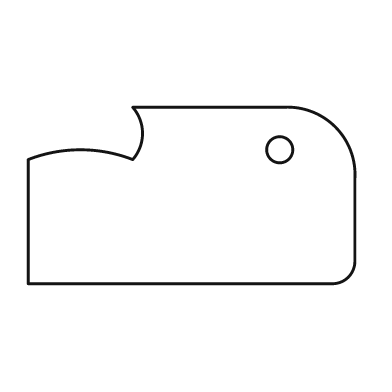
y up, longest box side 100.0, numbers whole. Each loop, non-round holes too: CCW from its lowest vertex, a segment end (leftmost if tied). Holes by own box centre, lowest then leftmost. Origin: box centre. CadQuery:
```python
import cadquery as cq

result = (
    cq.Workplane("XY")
    .moveTo(-50.0, -27.0)
    .lineTo(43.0, -27.0)
    .threePointArc((48.0, -25.0), (50.0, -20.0))
    .lineTo(50.0, 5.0)
    .threePointArc((44.0, 21.0), (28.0, 27.0))
    .lineTo(-18.0, 27.0)
    .threePointArc((-15.0, 19.0), (-18.0, 11.0))
    .threePointArc((-34.0, 14.0), (-50.0, 11.0))
    .close()
    .moveTo(27.0, 14.0)
    .circle(4.0)
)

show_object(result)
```